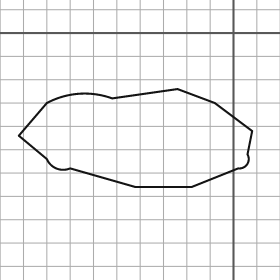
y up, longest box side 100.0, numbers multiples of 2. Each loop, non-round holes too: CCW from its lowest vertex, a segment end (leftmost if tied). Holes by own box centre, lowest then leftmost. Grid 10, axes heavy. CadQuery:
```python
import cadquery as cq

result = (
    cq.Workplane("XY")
    .moveTo(-42.0, -66.0)
    .lineTo(-18.0, -66.0)
    .lineTo(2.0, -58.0)
    .threePointArc((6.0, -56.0), (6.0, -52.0))
    .lineTo(8.0, -42.0)
    .lineTo(-8.0, -30.0)
    .lineTo(-24.0, -24.0)
    .lineTo(-52.0, -28.0)
    .threePointArc((-66.0, -26.0), (-80.0, -30.0))
    .lineTo(-92.0, -44.0)
    .lineTo(-80.0, -54.0)
    .threePointArc((-76.0, -58.0), (-70.0, -58.0))
    .close()
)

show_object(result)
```